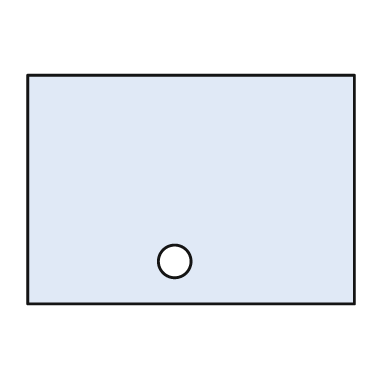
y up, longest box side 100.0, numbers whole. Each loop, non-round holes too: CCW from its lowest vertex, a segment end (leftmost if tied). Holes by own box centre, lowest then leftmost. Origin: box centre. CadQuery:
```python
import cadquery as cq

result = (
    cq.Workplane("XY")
    .moveTo(-50.0, -35.0)
    .lineTo(50.0, -35.0)
    .lineTo(50.0, 35.0)
    .lineTo(-50.0, 35.0)
    .close()
    .moveTo(-5.0, -22.0)
    .circle(5.0)
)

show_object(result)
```